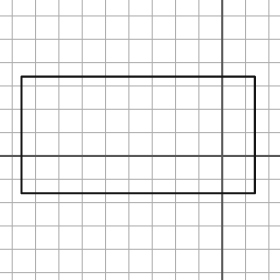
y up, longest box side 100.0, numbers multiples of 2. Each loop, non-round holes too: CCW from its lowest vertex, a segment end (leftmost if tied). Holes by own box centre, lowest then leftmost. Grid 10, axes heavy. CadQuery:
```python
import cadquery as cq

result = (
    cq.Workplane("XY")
    .moveTo(-86.0, -16.0)
    .lineTo(14.0, -16.0)
    .lineTo(14.0, 34.0)
    .lineTo(-86.0, 34.0)
    .close()
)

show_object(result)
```